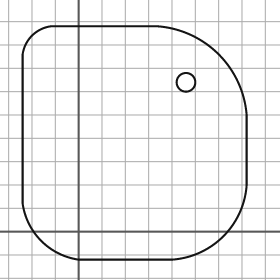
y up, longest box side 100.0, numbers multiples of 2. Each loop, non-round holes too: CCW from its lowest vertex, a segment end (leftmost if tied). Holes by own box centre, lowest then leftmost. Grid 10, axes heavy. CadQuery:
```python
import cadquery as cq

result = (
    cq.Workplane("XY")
    .moveTo(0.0, -12.0)
    .lineTo(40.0, -12.0)
    .threePointArc((62.0, -2.0), (72.0, 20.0))
    .lineTo(72.0, 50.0)
    .threePointArc((60.0, 76.0), (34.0, 88.0))
    .lineTo(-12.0, 88.0)
    .threePointArc((-20.0, 84.0), (-24.0, 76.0))
    .lineTo(-24.0, 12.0)
    .threePointArc((-16.0, -4.0), (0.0, -12.0))
    .close()
    .moveTo(46.0, 64.0)
    .circle(4.0)
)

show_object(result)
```